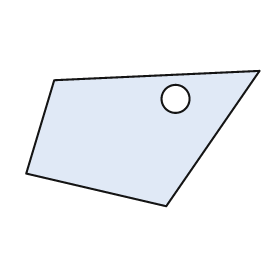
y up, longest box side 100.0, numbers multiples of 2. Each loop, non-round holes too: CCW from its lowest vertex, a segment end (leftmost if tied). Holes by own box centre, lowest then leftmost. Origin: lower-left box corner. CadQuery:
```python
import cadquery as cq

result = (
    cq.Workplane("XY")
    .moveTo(60.0, 0.0)
    .lineTo(100.0, 58.0)
    .lineTo(12.0, 54.0)
    .lineTo(0.0, 14.0)
    .close()
    .moveTo(64.0, 46.0)
    .circle(6.0)
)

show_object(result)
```